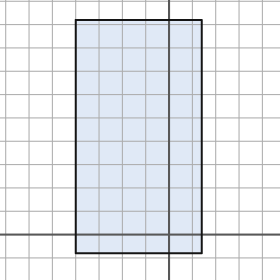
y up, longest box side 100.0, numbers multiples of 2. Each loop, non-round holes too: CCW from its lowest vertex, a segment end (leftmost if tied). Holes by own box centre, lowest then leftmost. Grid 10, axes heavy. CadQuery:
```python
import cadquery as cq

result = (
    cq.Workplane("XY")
    .moveTo(-40.0, -8.0)
    .lineTo(14.0, -8.0)
    .lineTo(14.0, 92.0)
    .lineTo(-40.0, 92.0)
    .close()
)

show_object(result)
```